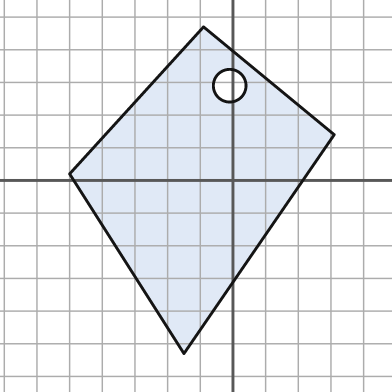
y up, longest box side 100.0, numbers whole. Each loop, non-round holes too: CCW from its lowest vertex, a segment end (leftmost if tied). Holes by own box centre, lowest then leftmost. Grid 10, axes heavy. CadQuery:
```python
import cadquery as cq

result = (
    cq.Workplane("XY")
    .moveTo(-15.0, -53.0)
    .lineTo(31.0, 14.0)
    .lineTo(-9.0, 47.0)
    .lineTo(-50.0, 2.0)
    .close()
    .moveTo(-1.0, 29.0)
    .circle(5.0)
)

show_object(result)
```